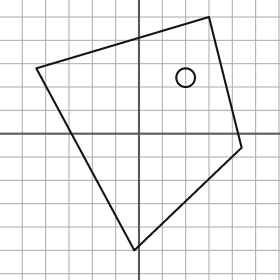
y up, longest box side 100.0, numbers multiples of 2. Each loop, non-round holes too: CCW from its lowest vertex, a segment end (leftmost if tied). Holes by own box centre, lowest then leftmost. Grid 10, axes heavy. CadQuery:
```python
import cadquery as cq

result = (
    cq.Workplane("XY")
    .moveTo(-2.0, -50.0)
    .lineTo(44.0, -6.0)
    .lineTo(30.0, 50.0)
    .lineTo(-44.0, 28.0)
    .close()
    .moveTo(20.0, 24.0)
    .circle(4.0)
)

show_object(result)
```